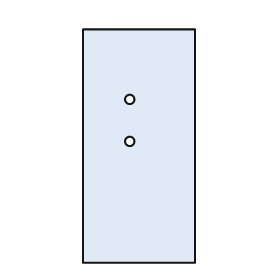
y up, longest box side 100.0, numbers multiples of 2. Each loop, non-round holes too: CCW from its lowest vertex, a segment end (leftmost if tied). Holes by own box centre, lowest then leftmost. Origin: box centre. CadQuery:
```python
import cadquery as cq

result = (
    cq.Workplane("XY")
    .moveTo(-24.0, -50.0)
    .lineTo(24.0, -50.0)
    .lineTo(24.0, 50.0)
    .lineTo(-24.0, 50.0)
    .close()
    .moveTo(-4.0, 2.0)
    .circle(2.0)
    .moveTo(-4.0, 20.0)
    .circle(2.0)
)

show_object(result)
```